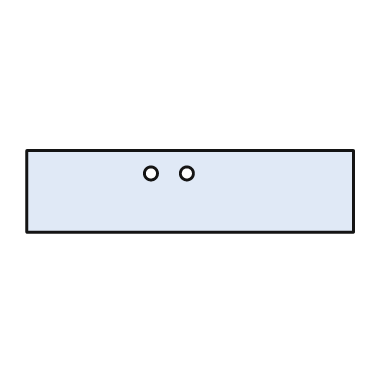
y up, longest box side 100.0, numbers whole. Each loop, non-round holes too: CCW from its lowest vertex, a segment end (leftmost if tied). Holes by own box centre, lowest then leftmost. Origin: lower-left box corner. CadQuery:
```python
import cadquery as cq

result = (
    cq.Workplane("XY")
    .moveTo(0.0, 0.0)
    .lineTo(100.0, 0.0)
    .lineTo(100.0, 25.0)
    .lineTo(0.0, 25.0)
    .close()
    .moveTo(38.0, 18.0)
    .circle(2.0)
    .moveTo(49.0, 18.0)
    .circle(2.0)
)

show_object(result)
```